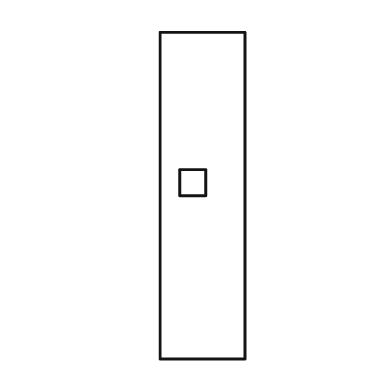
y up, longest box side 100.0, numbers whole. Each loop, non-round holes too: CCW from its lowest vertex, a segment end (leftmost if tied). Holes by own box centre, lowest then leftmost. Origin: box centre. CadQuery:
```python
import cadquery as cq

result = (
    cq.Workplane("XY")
    .moveTo(-13.0, -50.0)
    .lineTo(13.0, -50.0)
    .lineTo(13.0, 50.0)
    .lineTo(-13.0, 50.0)
    .close()
    .moveTo(-7.0, 0.0)
    .lineTo(1.0, 0.0)
    .lineTo(1.0, 8.0)
    .lineTo(-7.0, 8.0)
    .close()
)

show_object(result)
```